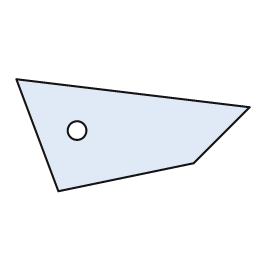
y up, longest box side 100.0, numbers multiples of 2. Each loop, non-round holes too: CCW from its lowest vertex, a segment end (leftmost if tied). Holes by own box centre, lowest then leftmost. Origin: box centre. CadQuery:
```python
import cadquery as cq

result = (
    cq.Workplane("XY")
    .moveTo(-32.0, -24.0)
    .lineTo(26.0, -12.0)
    .lineTo(50.0, 12.0)
    .lineTo(-50.0, 24.0)
    .close()
    .moveTo(-24.0, 2.0)
    .circle(4.0)
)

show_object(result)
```